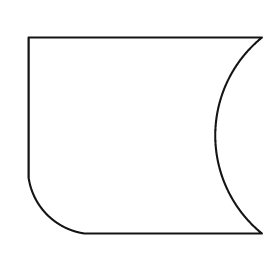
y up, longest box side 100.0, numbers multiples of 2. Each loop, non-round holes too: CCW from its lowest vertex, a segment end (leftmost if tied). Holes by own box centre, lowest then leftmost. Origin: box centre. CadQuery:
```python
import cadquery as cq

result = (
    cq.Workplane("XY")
    .moveTo(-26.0, -42.0)
    .lineTo(50.0, -42.0)
    .threePointArc((30.0, 0.0), (50.0, 42.0))
    .lineTo(-50.0, 42.0)
    .lineTo(-50.0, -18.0)
    .threePointArc((-42.0, -34.0), (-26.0, -42.0))
    .close()
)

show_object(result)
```